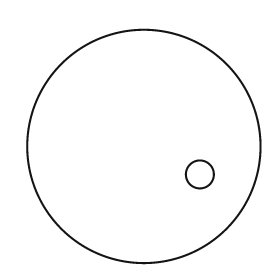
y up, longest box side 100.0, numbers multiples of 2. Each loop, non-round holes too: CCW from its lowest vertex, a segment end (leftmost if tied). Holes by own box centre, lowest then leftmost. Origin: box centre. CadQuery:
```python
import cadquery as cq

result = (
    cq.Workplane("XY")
    .moveTo(0.0, 0.0)
    .circle(50.0)
    .moveTo(24.0, -12.0)
    .circle(6.0)
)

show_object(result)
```